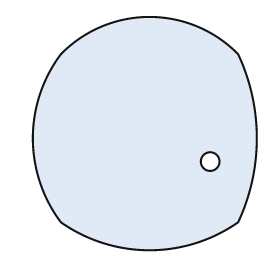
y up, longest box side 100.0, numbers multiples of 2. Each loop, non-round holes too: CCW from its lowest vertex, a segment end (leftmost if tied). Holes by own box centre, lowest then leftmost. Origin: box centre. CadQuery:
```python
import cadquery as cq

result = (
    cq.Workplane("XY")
    .moveTo(-36.0, -38.0)
    .threePointArc((2.0, -50.0), (40.0, -38.0))
    .threePointArc((48.0, -2.0), (40.0, 34.0))
    .threePointArc((2.0, 50.0), (-36.0, 34.0))
    .threePointArc((-48.0, -2.0), (-36.0, -38.0))
    .close()
    .moveTo(28.0, -12.0)
    .circle(4.0)
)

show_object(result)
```